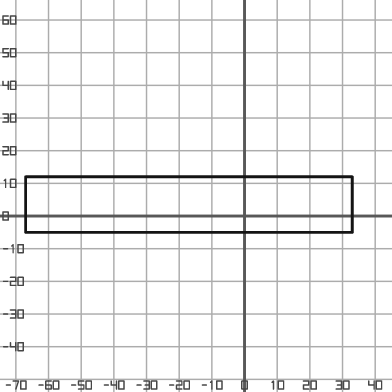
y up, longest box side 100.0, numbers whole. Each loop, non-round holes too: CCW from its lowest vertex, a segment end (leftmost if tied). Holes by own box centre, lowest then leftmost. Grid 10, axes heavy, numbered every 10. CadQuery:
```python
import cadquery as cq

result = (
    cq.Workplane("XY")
    .moveTo(-67.0, -5.0)
    .lineTo(33.0, -5.0)
    .lineTo(33.0, 12.0)
    .lineTo(-67.0, 12.0)
    .close()
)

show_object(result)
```